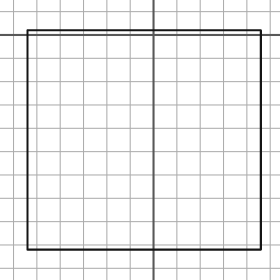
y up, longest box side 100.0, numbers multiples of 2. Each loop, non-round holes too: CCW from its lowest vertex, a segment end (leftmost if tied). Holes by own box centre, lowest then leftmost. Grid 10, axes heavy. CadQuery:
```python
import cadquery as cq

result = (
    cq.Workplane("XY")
    .moveTo(-54.0, -92.0)
    .lineTo(46.0, -92.0)
    .lineTo(46.0, 2.0)
    .lineTo(-54.0, 2.0)
    .close()
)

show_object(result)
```